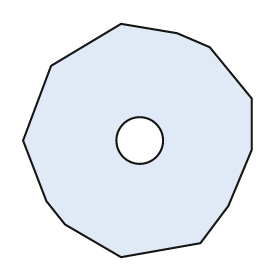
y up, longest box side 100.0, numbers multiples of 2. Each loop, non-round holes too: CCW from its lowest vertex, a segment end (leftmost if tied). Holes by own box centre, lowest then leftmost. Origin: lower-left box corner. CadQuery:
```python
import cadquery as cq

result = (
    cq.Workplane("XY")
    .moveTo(42.0, 0.0)
    .lineTo(76.0, 6.0)
    .lineTo(88.0, 22.0)
    .lineTo(98.0, 46.0)
    .lineTo(98.0, 68.0)
    .lineTo(80.0, 90.0)
    .lineTo(66.0, 96.0)
    .lineTo(42.0, 100.0)
    .lineTo(12.0, 82.0)
    .lineTo(0.0, 50.0)
    .lineTo(10.0, 24.0)
    .lineTo(18.0, 14.0)
    .close()
    .moveTo(50.0, 50.0)
    .circle(10.0)
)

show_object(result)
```